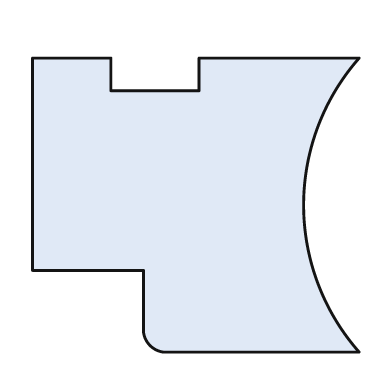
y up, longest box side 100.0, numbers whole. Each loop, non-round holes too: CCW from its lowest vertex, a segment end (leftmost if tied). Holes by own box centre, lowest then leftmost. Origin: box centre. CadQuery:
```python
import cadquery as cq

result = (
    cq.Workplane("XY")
    .moveTo(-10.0, -45.0)
    .lineTo(50.0, -45.0)
    .threePointArc((33.0, 0.0), (50.0, 45.0))
    .lineTo(1.0, 45.0)
    .lineTo(1.0, 35.0)
    .lineTo(-26.0, 35.0)
    .lineTo(-26.0, 45.0)
    .lineTo(-50.0, 45.0)
    .lineTo(-50.0, -20.0)
    .lineTo(-16.0, -20.0)
    .lineTo(-16.0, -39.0)
    .threePointArc((-14.0, -43.0), (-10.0, -45.0))
    .close()
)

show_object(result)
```